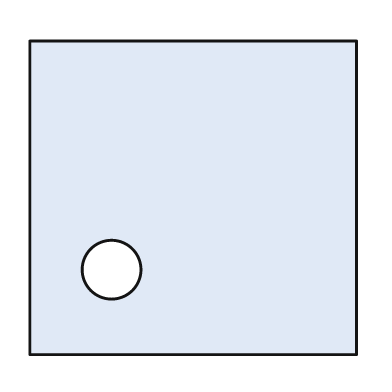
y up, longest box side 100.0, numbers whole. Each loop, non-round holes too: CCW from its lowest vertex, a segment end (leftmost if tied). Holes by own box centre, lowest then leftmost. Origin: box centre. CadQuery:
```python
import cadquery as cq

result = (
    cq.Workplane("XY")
    .moveTo(-50.0, -48.0)
    .lineTo(50.0, -48.0)
    .lineTo(50.0, 48.0)
    .lineTo(-50.0, 48.0)
    .close()
    .moveTo(-25.0, -22.0)
    .circle(9.0)
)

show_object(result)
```